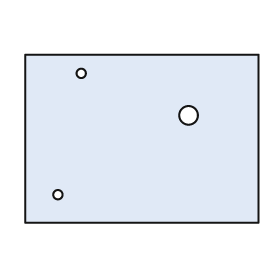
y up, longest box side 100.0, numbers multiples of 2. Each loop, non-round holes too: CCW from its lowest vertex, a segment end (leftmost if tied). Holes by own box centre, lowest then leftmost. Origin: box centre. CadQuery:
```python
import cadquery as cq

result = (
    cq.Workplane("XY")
    .moveTo(-50.0, -36.0)
    .lineTo(50.0, -36.0)
    .lineTo(50.0, 36.0)
    .lineTo(-50.0, 36.0)
    .close()
    .moveTo(-36.0, -24.0)
    .circle(2.0)
    .moveTo(20.0, 10.0)
    .circle(4.0)
    .moveTo(-26.0, 28.0)
    .circle(2.0)
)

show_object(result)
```